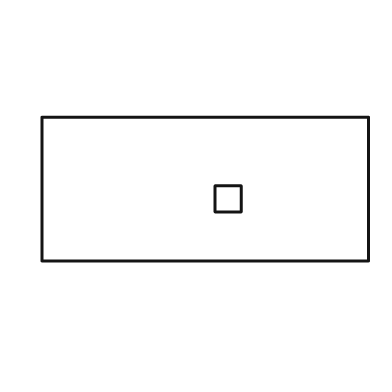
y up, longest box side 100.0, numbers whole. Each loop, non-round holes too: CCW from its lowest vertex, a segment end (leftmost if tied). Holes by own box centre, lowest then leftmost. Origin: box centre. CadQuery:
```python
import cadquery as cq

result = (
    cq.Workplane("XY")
    .moveTo(-50.0, -22.0)
    .lineTo(50.0, -22.0)
    .lineTo(50.0, 22.0)
    .lineTo(-50.0, 22.0)
    .close()
    .moveTo(3.0, -7.0)
    .lineTo(11.0, -7.0)
    .lineTo(11.0, 1.0)
    .lineTo(3.0, 1.0)
    .close()
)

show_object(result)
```